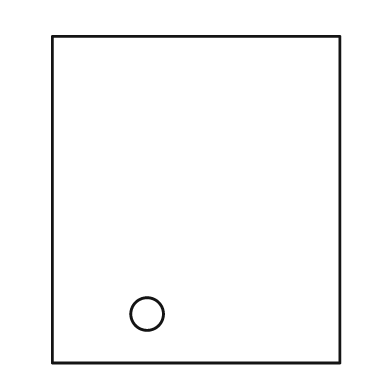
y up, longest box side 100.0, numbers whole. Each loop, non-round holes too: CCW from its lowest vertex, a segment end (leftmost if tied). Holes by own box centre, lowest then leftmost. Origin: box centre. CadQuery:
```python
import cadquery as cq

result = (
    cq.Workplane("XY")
    .moveTo(-44.0, -50.0)
    .lineTo(44.0, -50.0)
    .lineTo(44.0, 50.0)
    .lineTo(-44.0, 50.0)
    .close()
    .moveTo(-15.0, -35.0)
    .circle(5.0)
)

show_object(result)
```